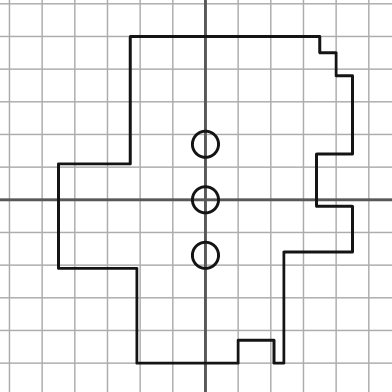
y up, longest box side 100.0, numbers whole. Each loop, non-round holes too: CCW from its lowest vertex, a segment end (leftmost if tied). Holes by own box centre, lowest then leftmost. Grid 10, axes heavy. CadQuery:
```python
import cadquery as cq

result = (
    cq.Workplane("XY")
    .moveTo(-21.0, -50.0)
    .lineTo(10.0, -50.0)
    .lineTo(10.0, -43.0)
    .lineTo(21.0, -43.0)
    .lineTo(21.0, -50.0)
    .lineTo(24.0, -50.0)
    .lineTo(24.0, -16.0)
    .lineTo(45.0, -16.0)
    .lineTo(45.0, -2.0)
    .lineTo(34.0, -2.0)
    .lineTo(34.0, 14.0)
    .lineTo(45.0, 14.0)
    .lineTo(45.0, 38.0)
    .lineTo(40.0, 38.0)
    .lineTo(40.0, 45.0)
    .lineTo(35.0, 45.0)
    .lineTo(35.0, 50.0)
    .lineTo(-23.0, 50.0)
    .lineTo(-23.0, 11.0)
    .lineTo(-45.0, 11.0)
    .lineTo(-45.0, -21.0)
    .lineTo(-21.0, -21.0)
    .close()
    .moveTo(0.0, -17.0)
    .circle(4.0)
    .moveTo(0.0, 0.0)
    .circle(4.0)
    .moveTo(0.0, 17.0)
    .circle(4.0)
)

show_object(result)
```